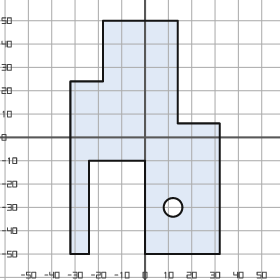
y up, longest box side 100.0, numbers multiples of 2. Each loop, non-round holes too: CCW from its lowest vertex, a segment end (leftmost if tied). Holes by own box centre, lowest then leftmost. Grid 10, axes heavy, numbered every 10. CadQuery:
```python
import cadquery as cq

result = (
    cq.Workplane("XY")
    .moveTo(-32.0, -50.0)
    .lineTo(-24.0, -50.0)
    .lineTo(-24.0, -10.0)
    .lineTo(0.0, -10.0)
    .lineTo(0.0, -50.0)
    .lineTo(32.0, -50.0)
    .lineTo(32.0, 6.0)
    .lineTo(14.0, 6.0)
    .lineTo(14.0, 50.0)
    .lineTo(-18.0, 50.0)
    .lineTo(-18.0, 24.0)
    .lineTo(-32.0, 24.0)
    .close()
    .moveTo(12.0, -30.0)
    .circle(4.0)
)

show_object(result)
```